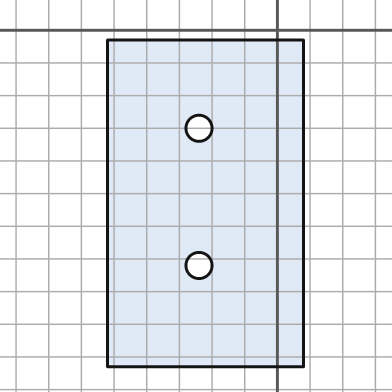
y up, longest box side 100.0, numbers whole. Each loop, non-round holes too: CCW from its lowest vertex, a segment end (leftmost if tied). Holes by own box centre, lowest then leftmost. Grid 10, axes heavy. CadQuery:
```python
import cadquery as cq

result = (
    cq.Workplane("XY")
    .moveTo(-52.0, -103.0)
    .lineTo(8.0, -103.0)
    .lineTo(8.0, -3.0)
    .lineTo(-52.0, -3.0)
    .close()
    .moveTo(-24.0, -72.0)
    .circle(4.0)
    .moveTo(-24.0, -30.0)
    .circle(4.0)
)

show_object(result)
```